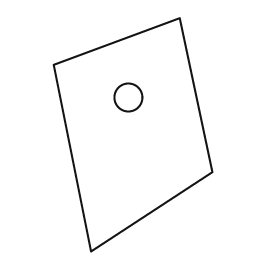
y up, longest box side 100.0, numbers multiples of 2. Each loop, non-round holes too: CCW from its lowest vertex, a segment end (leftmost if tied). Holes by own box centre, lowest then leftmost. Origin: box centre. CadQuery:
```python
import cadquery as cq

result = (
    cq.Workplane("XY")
    .moveTo(-18.0, -50.0)
    .lineTo(34.0, -16.0)
    .lineTo(20.0, 50.0)
    .lineTo(-34.0, 30.0)
    .close()
    .moveTo(-2.0, 16.0)
    .circle(6.0)
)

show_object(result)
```